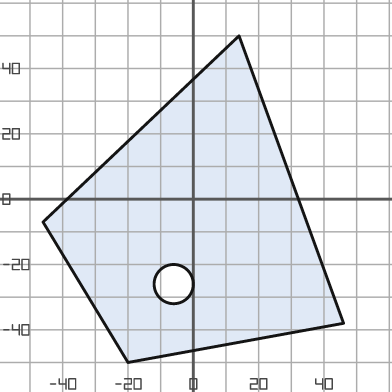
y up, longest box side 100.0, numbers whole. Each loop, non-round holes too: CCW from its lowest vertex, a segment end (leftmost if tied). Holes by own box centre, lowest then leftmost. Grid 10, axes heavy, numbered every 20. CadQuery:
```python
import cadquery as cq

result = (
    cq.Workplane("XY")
    .moveTo(-20.0, -50.0)
    .lineTo(46.0, -38.0)
    .lineTo(14.0, 50.0)
    .lineTo(-46.0, -7.0)
    .close()
    .moveTo(-6.0, -26.0)
    .circle(6.0)
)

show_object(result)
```